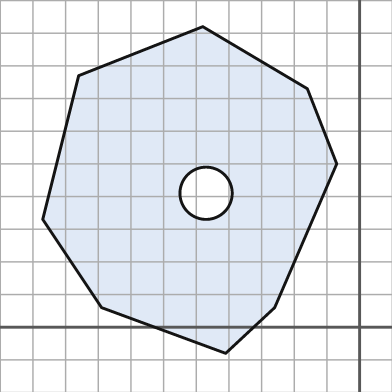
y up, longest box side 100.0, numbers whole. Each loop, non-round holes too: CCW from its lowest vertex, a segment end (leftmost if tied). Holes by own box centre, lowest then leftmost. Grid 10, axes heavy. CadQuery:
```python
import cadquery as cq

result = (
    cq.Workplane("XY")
    .moveTo(-41.0, -8.0)
    .lineTo(-26.0, 6.0)
    .lineTo(-7.0, 50.0)
    .lineTo(-16.0, 73.0)
    .lineTo(-48.0, 92.0)
    .lineTo(-86.0, 77.0)
    .lineTo(-97.0, 33.0)
    .lineTo(-79.0, 6.0)
    .close()
    .moveTo(-47.0, 41.0)
    .circle(8.0)
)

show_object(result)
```